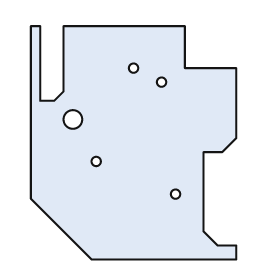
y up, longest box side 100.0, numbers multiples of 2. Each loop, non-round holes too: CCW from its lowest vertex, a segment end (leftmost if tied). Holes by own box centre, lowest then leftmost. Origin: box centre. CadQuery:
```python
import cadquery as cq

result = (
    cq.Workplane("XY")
    .moveTo(-18.0, -50.0)
    .lineTo(44.0, -50.0)
    .lineTo(44.0, -44.0)
    .lineTo(36.0, -44.0)
    .lineTo(30.0, -38.0)
    .lineTo(30.0, -4.0)
    .lineTo(38.0, -4.0)
    .lineTo(44.0, 2.0)
    .lineTo(44.0, 32.0)
    .lineTo(22.0, 32.0)
    .lineTo(22.0, 50.0)
    .lineTo(-30.0, 50.0)
    .lineTo(-30.0, 22.0)
    .lineTo(-34.0, 18.0)
    .lineTo(-40.0, 18.0)
    .lineTo(-40.0, 50.0)
    .lineTo(-44.0, 50.0)
    .lineTo(-44.0, -24.0)
    .close()
    .moveTo(18.0, -22.0)
    .circle(2.0)
    .moveTo(-16.0, -8.0)
    .circle(2.0)
    .moveTo(-26.0, 10.0)
    .circle(4.0)
    .moveTo(12.0, 26.0)
    .circle(2.0)
    .moveTo(0.0, 32.0)
    .circle(2.0)
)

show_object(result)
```